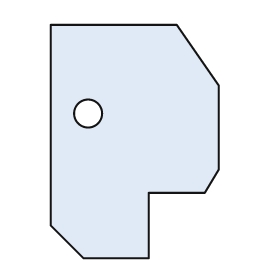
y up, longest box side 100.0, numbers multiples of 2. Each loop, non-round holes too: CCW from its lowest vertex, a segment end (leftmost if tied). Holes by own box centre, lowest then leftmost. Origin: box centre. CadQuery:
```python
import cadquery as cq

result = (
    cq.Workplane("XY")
    .moveTo(-22.0, -50.0)
    .lineTo(6.0, -50.0)
    .lineTo(6.0, -22.0)
    .lineTo(30.0, -22.0)
    .lineTo(36.0, -12.0)
    .lineTo(36.0, 24.0)
    .lineTo(18.0, 50.0)
    .lineTo(-36.0, 50.0)
    .lineTo(-36.0, -36.0)
    .close()
    .moveTo(-20.0, 12.0)
    .circle(6.0)
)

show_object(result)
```